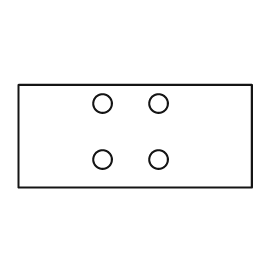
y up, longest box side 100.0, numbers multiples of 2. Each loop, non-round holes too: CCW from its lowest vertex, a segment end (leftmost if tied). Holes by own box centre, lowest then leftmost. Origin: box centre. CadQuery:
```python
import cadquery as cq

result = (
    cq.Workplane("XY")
    .moveTo(-50.0, -22.0)
    .lineTo(50.0, -22.0)
    .lineTo(50.0, 22.0)
    .lineTo(-50.0, 22.0)
    .close()
    .moveTo(-14.0, -10.0)
    .circle(4.0)
    .moveTo(10.0, -10.0)
    .circle(4.0)
    .moveTo(-14.0, 14.0)
    .circle(4.0)
    .moveTo(10.0, 14.0)
    .circle(4.0)
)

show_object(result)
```